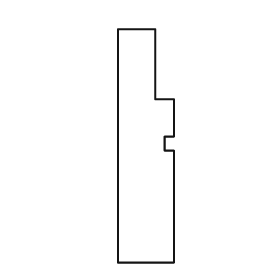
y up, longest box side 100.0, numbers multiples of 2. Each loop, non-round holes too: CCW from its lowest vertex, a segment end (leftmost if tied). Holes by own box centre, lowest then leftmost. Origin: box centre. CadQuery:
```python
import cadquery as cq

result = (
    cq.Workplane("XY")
    .moveTo(-12.0, -50.0)
    .lineTo(12.0, -50.0)
    .lineTo(12.0, -2.0)
    .lineTo(8.0, -2.0)
    .lineTo(8.0, 4.0)
    .lineTo(12.0, 4.0)
    .lineTo(12.0, 20.0)
    .lineTo(4.0, 20.0)
    .lineTo(4.0, 50.0)
    .lineTo(-12.0, 50.0)
    .close()
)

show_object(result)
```